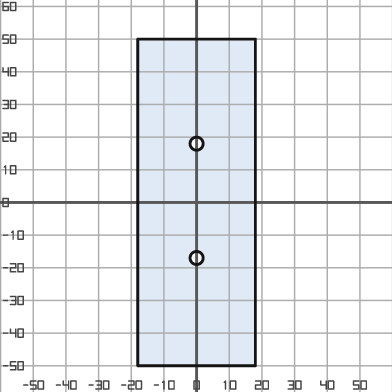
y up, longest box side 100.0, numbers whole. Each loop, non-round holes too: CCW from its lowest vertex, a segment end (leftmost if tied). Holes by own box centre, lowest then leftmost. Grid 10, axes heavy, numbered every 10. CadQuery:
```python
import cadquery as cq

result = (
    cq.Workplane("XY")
    .moveTo(-18.0, -50.0)
    .lineTo(18.0, -50.0)
    .lineTo(18.0, 50.0)
    .lineTo(-18.0, 50.0)
    .close()
    .moveTo(0.0, -17.0)
    .circle(2.0)
    .moveTo(0.0, 18.0)
    .circle(2.0)
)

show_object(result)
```